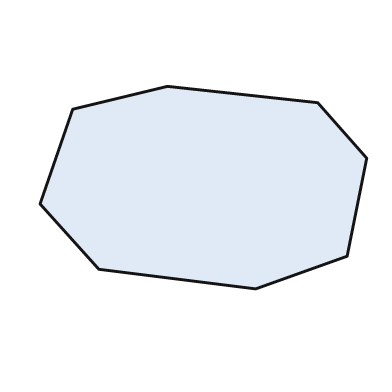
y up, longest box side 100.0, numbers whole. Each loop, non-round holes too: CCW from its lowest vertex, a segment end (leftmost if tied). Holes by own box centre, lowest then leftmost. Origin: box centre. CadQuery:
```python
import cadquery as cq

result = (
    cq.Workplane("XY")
    .moveTo(16.0, -31.0)
    .lineTo(44.0, -21.0)
    .lineTo(50.0, 9.0)
    .lineTo(35.0, 26.0)
    .lineTo(-11.0, 31.0)
    .lineTo(-40.0, 24.0)
    .lineTo(-50.0, -5.0)
    .lineTo(-32.0, -25.0)
    .close()
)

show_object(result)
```